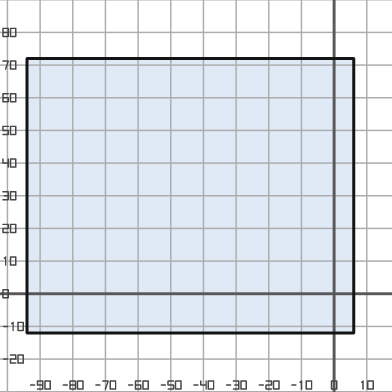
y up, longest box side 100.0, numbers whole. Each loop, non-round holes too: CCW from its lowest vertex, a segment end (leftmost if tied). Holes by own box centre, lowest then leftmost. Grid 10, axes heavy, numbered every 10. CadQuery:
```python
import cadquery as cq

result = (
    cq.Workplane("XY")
    .moveTo(-94.0, -12.0)
    .lineTo(6.0, -12.0)
    .lineTo(6.0, 72.0)
    .lineTo(-94.0, 72.0)
    .close()
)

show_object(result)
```